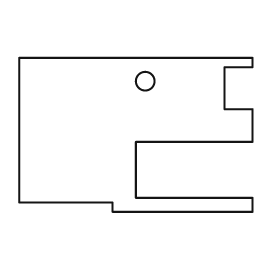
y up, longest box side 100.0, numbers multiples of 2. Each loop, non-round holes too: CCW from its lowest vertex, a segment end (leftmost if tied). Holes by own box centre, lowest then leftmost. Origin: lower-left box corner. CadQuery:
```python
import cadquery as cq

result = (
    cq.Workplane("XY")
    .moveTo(40.0, 0.0)
    .lineTo(100.0, 0.0)
    .lineTo(100.0, 6.0)
    .lineTo(50.0, 6.0)
    .lineTo(50.0, 30.0)
    .lineTo(100.0, 30.0)
    .lineTo(100.0, 44.0)
    .lineTo(88.0, 44.0)
    .lineTo(88.0, 62.0)
    .lineTo(100.0, 62.0)
    .lineTo(100.0, 66.0)
    .lineTo(0.0, 66.0)
    .lineTo(0.0, 4.0)
    .lineTo(40.0, 4.0)
    .close()
    .moveTo(54.0, 56.0)
    .circle(4.0)
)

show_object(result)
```